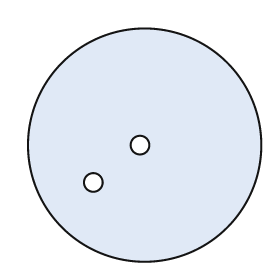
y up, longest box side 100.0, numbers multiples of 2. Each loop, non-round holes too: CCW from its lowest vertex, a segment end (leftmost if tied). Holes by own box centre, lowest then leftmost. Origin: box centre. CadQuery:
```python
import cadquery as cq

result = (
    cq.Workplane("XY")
    .moveTo(0.0, 0.0)
    .circle(50.0)
    .moveTo(-22.0, -16.0)
    .circle(4.0)
    .moveTo(-2.0, 0.0)
    .circle(4.0)
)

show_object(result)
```